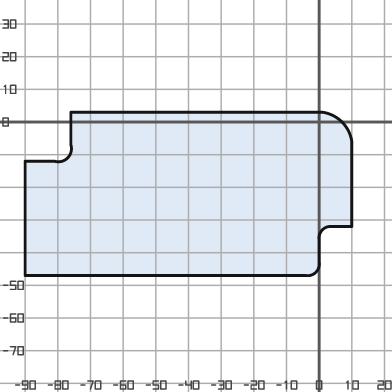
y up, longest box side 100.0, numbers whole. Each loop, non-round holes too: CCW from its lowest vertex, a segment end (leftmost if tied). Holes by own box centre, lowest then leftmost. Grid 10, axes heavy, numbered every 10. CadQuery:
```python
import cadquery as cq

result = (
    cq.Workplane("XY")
    .moveTo(-90.0, -47.0)
    .lineTo(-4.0, -47.0)
    .threePointArc((-1.0, -46.0), (0.0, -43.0))
    .lineTo(0.0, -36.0)
    .threePointArc((1.0, -33.0), (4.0, -32.0))
    .lineTo(10.0, -32.0)
    .lineTo(10.0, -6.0)
    .threePointArc((7.0, 0.0), (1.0, 3.0))
    .lineTo(-76.0, 3.0)
    .lineTo(-76.0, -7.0)
    .threePointArc((-77.0, -11.0), (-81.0, -12.0))
    .lineTo(-90.0, -12.0)
    .close()
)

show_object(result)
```